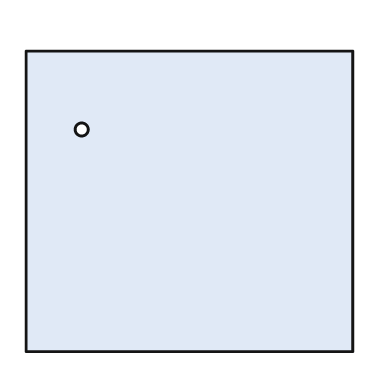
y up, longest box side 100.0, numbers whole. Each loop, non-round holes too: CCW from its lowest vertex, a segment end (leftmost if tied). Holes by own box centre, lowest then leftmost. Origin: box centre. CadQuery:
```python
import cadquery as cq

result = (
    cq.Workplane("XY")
    .moveTo(-50.0, -46.0)
    .lineTo(50.0, -46.0)
    .lineTo(50.0, 46.0)
    .lineTo(-50.0, 46.0)
    .close()
    .moveTo(-33.0, 22.0)
    .circle(2.0)
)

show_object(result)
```